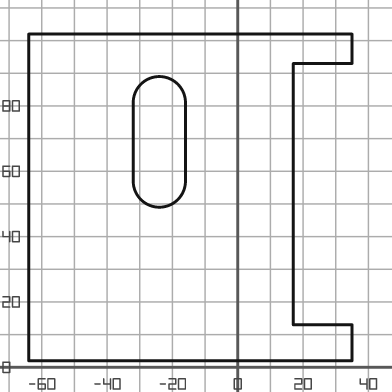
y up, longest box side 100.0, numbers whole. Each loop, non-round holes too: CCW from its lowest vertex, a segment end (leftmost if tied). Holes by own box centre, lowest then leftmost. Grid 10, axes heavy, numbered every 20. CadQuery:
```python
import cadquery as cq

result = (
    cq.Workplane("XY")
    .moveTo(-64.0, 2.0)
    .lineTo(35.0, 2.0)
    .lineTo(35.0, 13.0)
    .lineTo(17.0, 13.0)
    .lineTo(17.0, 93.0)
    .lineTo(35.0, 93.0)
    .lineTo(35.0, 102.0)
    .lineTo(-64.0, 102.0)
    .close()
    .moveTo(-32.0, 57.0)
    .threePointArc((-24.0, 49.0), (-16.0, 57.0))
    .lineTo(-16.0, 81.0)
    .threePointArc((-24.0, 89.0), (-32.0, 81.0))
    .close()
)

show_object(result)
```